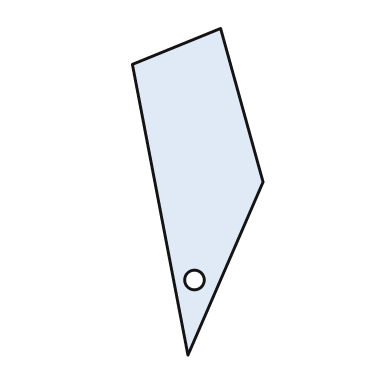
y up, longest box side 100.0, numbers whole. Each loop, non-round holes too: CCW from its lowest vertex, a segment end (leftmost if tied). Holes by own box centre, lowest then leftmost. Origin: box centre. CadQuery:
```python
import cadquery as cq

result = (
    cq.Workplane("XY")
    .moveTo(-3.0, -50.0)
    .lineTo(20.0, 3.0)
    .lineTo(7.0, 50.0)
    .lineTo(-20.0, 39.0)
    .close()
    .moveTo(-1.0, -27.0)
    .circle(3.0)
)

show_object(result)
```